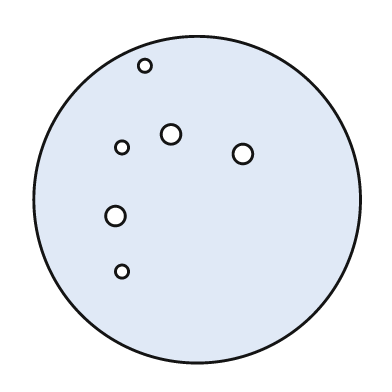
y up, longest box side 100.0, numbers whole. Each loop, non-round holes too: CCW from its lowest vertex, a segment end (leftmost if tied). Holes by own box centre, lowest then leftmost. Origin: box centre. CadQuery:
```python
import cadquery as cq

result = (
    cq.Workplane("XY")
    .moveTo(0.0, 0.0)
    .circle(50.0)
    .moveTo(-23.0, -22.0)
    .circle(2.0)
    .moveTo(-25.0, -5.0)
    .circle(3.0)
    .moveTo(14.0, 14.0)
    .circle(3.0)
    .moveTo(-23.0, 16.0)
    .circle(2.0)
    .moveTo(-8.0, 20.0)
    .circle(3.0)
    .moveTo(-16.0, 41.0)
    .circle(2.0)
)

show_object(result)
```